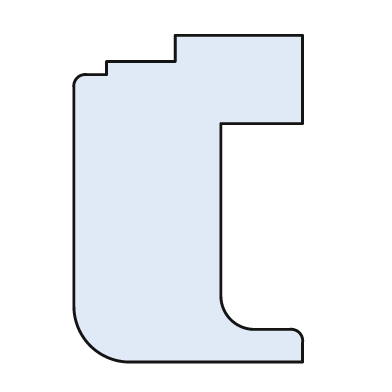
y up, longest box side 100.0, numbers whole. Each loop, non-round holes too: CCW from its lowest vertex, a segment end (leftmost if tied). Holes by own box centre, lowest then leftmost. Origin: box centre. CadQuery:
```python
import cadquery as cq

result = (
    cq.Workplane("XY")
    .moveTo(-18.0, -50.0)
    .lineTo(35.0, -50.0)
    .lineTo(35.0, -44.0)
    .threePointArc((34.0, -41.0), (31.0, -40.0))
    .lineTo(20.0, -40.0)
    .threePointArc((13.0, -37.0), (10.0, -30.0))
    .lineTo(10.0, 23.0)
    .lineTo(35.0, 23.0)
    .lineTo(35.0, 50.0)
    .lineTo(-4.0, 50.0)
    .lineTo(-4.0, 42.0)
    .lineTo(-25.0, 42.0)
    .lineTo(-25.0, 38.0)
    .lineTo(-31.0, 38.0)
    .threePointArc((-34.0, 37.0), (-35.0, 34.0))
    .lineTo(-35.0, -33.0)
    .threePointArc((-30.0, -45.0), (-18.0, -50.0))
    .close()
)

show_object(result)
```